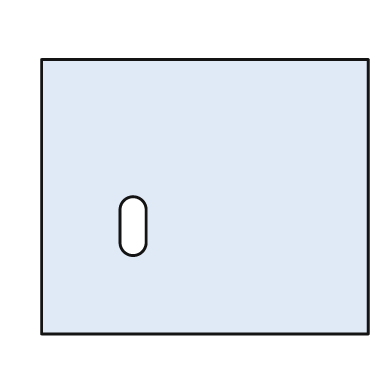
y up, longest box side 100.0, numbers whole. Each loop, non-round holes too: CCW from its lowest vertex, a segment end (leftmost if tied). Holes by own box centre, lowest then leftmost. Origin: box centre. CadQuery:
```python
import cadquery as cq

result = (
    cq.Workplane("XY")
    .moveTo(-50.0, -42.0)
    .lineTo(50.0, -42.0)
    .lineTo(50.0, 42.0)
    .lineTo(-50.0, 42.0)
    .close()
    .moveTo(-26.0, -14.0)
    .threePointArc((-22.0, -18.0), (-18.0, -14.0))
    .lineTo(-18.0, -4.0)
    .threePointArc((-22.0, 0.0), (-26.0, -4.0))
    .close()
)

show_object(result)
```